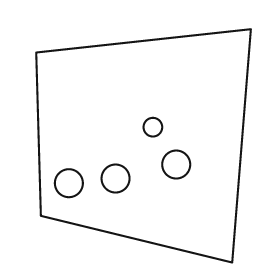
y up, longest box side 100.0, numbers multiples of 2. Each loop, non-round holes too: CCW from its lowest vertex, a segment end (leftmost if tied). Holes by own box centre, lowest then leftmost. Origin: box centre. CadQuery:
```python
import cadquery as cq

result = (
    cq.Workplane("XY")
    .moveTo(38.0, -50.0)
    .lineTo(46.0, 50.0)
    .lineTo(-46.0, 40.0)
    .lineTo(-44.0, -30.0)
    .close()
    .moveTo(-32.0, -16.0)
    .circle(6.0)
    .moveTo(-12.0, -14.0)
    .circle(6.0)
    .moveTo(14.0, -8.0)
    .circle(6.0)
    .moveTo(4.0, 8.0)
    .circle(4.0)
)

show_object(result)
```